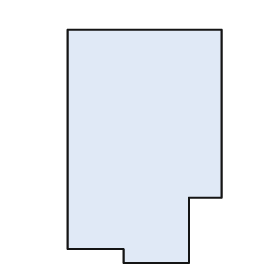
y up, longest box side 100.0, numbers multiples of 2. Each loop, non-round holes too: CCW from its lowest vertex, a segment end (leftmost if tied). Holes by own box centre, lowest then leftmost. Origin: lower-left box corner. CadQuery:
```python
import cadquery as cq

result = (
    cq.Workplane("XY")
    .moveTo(24.0, 0.0)
    .lineTo(52.0, 0.0)
    .lineTo(52.0, 28.0)
    .lineTo(66.0, 28.0)
    .lineTo(66.0, 100.0)
    .lineTo(0.0, 100.0)
    .lineTo(0.0, 6.0)
    .lineTo(24.0, 6.0)
    .close()
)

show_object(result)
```